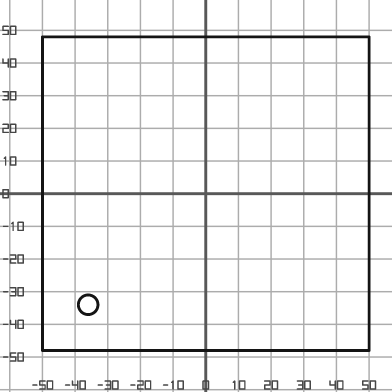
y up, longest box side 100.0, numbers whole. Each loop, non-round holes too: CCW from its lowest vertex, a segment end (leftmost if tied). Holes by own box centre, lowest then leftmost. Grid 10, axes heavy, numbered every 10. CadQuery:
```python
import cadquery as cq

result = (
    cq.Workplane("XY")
    .moveTo(-50.0, -48.0)
    .lineTo(50.0, -48.0)
    .lineTo(50.0, 48.0)
    .lineTo(-50.0, 48.0)
    .close()
    .moveTo(-36.0, -34.0)
    .circle(3.0)
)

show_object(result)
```